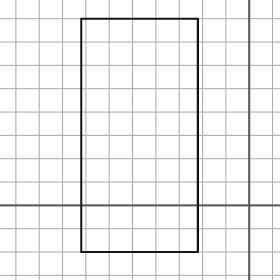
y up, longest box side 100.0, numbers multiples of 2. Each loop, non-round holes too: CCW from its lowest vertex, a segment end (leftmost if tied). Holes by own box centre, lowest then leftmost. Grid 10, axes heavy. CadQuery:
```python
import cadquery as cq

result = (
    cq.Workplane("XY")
    .moveTo(-72.0, -20.0)
    .lineTo(-22.0, -20.0)
    .lineTo(-22.0, 80.0)
    .lineTo(-72.0, 80.0)
    .close()
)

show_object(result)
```